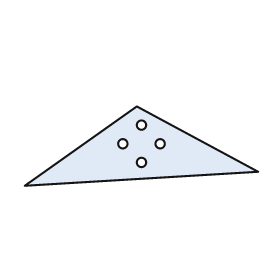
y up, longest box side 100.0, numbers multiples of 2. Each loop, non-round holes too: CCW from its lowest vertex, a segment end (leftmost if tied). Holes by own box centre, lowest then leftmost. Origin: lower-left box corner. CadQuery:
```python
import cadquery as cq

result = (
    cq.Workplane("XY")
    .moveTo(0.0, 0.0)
    .lineTo(100.0, 6.0)
    .lineTo(48.0, 34.0)
    .close()
    .moveTo(50.0, 10.0)
    .circle(2.0)
    .moveTo(42.0, 18.0)
    .circle(2.0)
    .moveTo(58.0, 18.0)
    .circle(2.0)
    .moveTo(50.0, 26.0)
    .circle(2.0)
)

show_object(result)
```